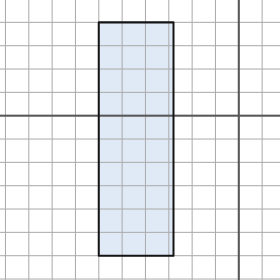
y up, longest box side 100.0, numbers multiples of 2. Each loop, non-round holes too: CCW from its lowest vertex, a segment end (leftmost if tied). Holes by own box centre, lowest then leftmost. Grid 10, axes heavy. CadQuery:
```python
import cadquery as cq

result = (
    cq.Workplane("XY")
    .moveTo(-60.0, -60.0)
    .lineTo(-28.0, -60.0)
    .lineTo(-28.0, 40.0)
    .lineTo(-60.0, 40.0)
    .close()
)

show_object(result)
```